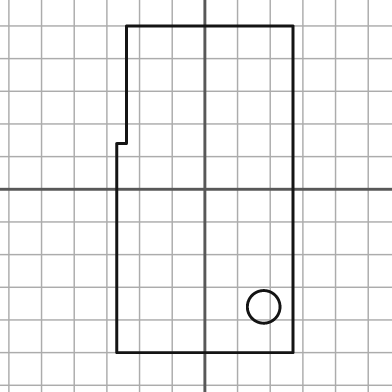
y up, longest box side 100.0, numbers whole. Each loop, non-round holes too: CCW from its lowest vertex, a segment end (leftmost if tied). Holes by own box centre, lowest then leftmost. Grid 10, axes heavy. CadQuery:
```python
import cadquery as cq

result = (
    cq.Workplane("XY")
    .moveTo(-27.0, -50.0)
    .lineTo(27.0, -50.0)
    .lineTo(27.0, 50.0)
    .lineTo(-24.0, 50.0)
    .lineTo(-24.0, 14.0)
    .lineTo(-27.0, 14.0)
    .close()
    .moveTo(18.0, -36.0)
    .circle(5.0)
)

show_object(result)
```